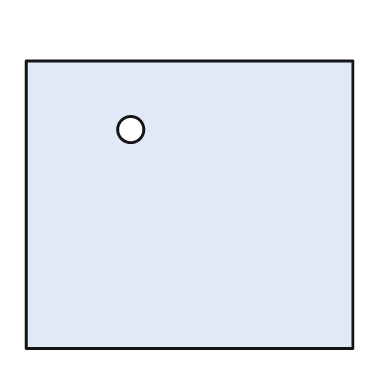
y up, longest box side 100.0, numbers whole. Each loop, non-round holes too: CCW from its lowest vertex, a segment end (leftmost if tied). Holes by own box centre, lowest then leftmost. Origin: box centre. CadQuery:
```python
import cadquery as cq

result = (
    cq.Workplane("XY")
    .moveTo(-50.0, -44.0)
    .lineTo(50.0, -44.0)
    .lineTo(50.0, 44.0)
    .lineTo(-50.0, 44.0)
    .close()
    .moveTo(-18.0, 23.0)
    .circle(4.0)
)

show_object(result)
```